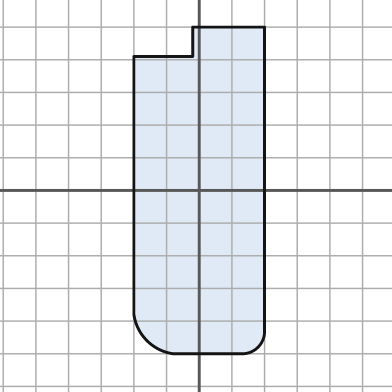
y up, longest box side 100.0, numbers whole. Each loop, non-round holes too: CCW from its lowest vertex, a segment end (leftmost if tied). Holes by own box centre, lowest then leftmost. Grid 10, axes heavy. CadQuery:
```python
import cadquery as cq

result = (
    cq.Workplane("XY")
    .moveTo(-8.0, -50.0)
    .lineTo(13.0, -50.0)
    .threePointArc((18.0, -48.0), (20.0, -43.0))
    .lineTo(20.0, 50.0)
    .lineTo(-2.0, 50.0)
    .lineTo(-2.0, 41.0)
    .lineTo(-20.0, 41.0)
    .lineTo(-20.0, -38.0)
    .threePointArc((-16.0, -46.0), (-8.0, -50.0))
    .close()
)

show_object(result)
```